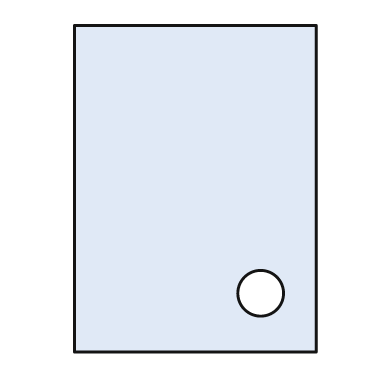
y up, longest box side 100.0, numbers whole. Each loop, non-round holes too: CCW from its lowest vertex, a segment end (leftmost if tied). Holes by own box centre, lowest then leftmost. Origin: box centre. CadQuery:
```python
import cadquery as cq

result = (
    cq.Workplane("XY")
    .moveTo(-37.0, -50.0)
    .lineTo(37.0, -50.0)
    .lineTo(37.0, 50.0)
    .lineTo(-37.0, 50.0)
    .close()
    .moveTo(20.0, -32.0)
    .circle(7.0)
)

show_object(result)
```